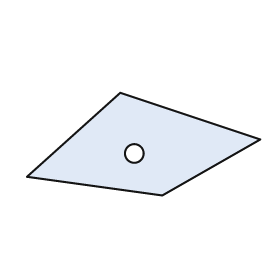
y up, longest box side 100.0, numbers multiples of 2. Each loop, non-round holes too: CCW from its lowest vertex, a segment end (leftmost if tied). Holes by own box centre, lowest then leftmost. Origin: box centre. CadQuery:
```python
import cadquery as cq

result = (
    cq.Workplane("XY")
    .moveTo(8.0, -22.0)
    .lineTo(50.0, 2.0)
    .lineTo(-10.0, 22.0)
    .lineTo(-50.0, -14.0)
    .close()
    .moveTo(-4.0, -4.0)
    .circle(4.0)
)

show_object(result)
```